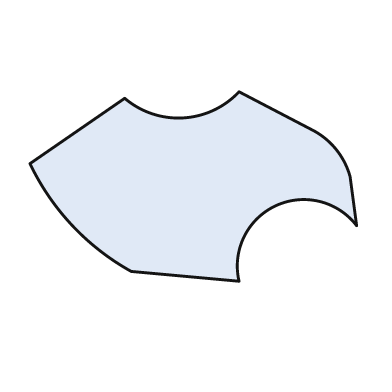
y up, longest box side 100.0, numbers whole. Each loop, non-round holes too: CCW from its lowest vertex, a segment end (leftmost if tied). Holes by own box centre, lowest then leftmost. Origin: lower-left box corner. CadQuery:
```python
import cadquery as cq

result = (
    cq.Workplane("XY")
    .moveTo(64.0, 0.0)
    .threePointArc((75.0, 23.0), (100.0, 17.0))
    .lineTo(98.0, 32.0)
    .threePointArc((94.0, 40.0), (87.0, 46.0))
    .lineTo(64.0, 58.0)
    .threePointArc((47.0, 50.0), (29.0, 56.0))
    .lineTo(0.0, 36.0)
    .threePointArc((13.0, 17.0), (31.0, 3.0))
    .close()
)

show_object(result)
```